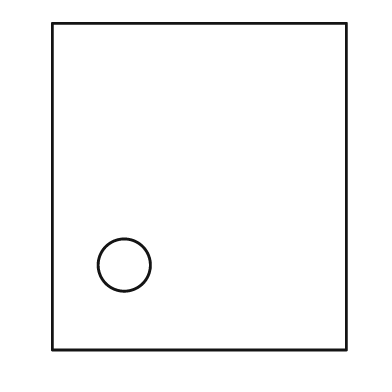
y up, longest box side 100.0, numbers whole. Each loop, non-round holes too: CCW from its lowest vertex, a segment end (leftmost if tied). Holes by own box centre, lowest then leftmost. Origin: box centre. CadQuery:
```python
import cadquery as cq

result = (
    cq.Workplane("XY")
    .moveTo(-45.0, -50.0)
    .lineTo(45.0, -50.0)
    .lineTo(45.0, 50.0)
    .lineTo(-45.0, 50.0)
    .close()
    .moveTo(-23.0, -24.0)
    .circle(8.0)
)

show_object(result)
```